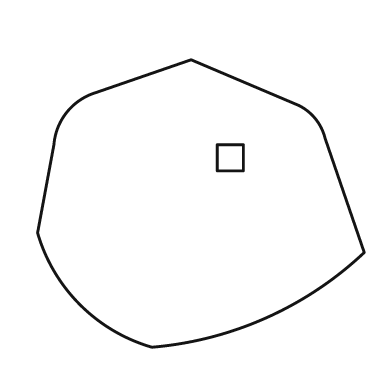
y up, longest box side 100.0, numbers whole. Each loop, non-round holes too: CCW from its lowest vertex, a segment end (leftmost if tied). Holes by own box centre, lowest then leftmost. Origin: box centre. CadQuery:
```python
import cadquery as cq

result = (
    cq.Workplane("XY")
    .moveTo(-15.0, -44.0)
    .threePointArc((20.0, -35.0), (50.0, -15.0))
    .lineTo(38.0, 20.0)
    .threePointArc((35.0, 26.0), (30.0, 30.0))
    .lineTo(-3.0, 44.0)
    .lineTo(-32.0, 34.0)
    .threePointArc((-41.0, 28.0), (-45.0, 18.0))
    .lineTo(-50.0, -9.0)
    .threePointArc((-37.0, -31.0), (-15.0, -44.0))
    .close()
    .moveTo(5.0, 10.0)
    .lineTo(13.0, 10.0)
    .lineTo(13.0, 18.0)
    .lineTo(5.0, 18.0)
    .close()
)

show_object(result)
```